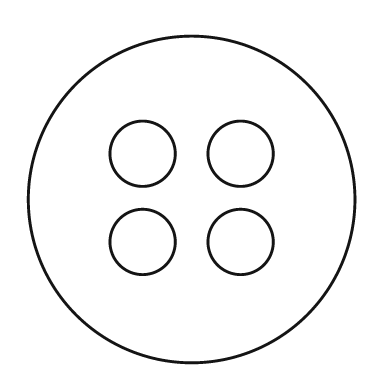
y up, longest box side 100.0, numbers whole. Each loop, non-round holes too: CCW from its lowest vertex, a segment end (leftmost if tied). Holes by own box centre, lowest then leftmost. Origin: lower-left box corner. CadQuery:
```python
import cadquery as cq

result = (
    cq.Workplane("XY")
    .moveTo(50.0, 50.0)
    .circle(50.0)
    .moveTo(35.0, 37.0)
    .circle(10.0)
    .moveTo(65.0, 37.0)
    .circle(10.0)
    .moveTo(35.0, 64.0)
    .circle(10.0)
    .moveTo(65.0, 64.0)
    .circle(10.0)
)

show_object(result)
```